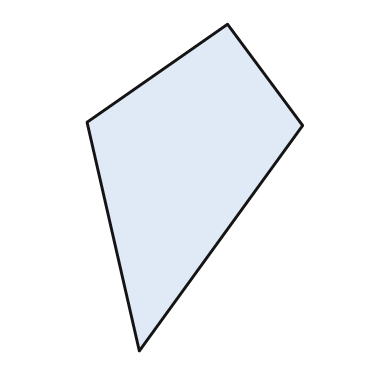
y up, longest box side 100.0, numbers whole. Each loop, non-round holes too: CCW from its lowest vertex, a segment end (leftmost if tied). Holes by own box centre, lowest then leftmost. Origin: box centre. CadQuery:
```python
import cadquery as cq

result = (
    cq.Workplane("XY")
    .moveTo(-17.0, -50.0)
    .lineTo(33.0, 19.0)
    .lineTo(10.0, 50.0)
    .lineTo(-33.0, 20.0)
    .close()
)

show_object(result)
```